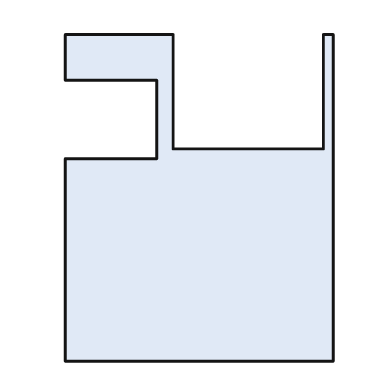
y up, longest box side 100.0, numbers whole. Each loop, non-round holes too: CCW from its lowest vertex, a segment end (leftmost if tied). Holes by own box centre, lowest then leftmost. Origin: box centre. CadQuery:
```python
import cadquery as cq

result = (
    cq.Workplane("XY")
    .moveTo(-41.0, -50.0)
    .lineTo(41.0, -50.0)
    .lineTo(41.0, 50.0)
    .lineTo(38.0, 50.0)
    .lineTo(38.0, 15.0)
    .lineTo(-8.0, 15.0)
    .lineTo(-8.0, 50.0)
    .lineTo(-41.0, 50.0)
    .lineTo(-41.0, 36.0)
    .lineTo(-13.0, 36.0)
    .lineTo(-13.0, 12.0)
    .lineTo(-41.0, 12.0)
    .close()
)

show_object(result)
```